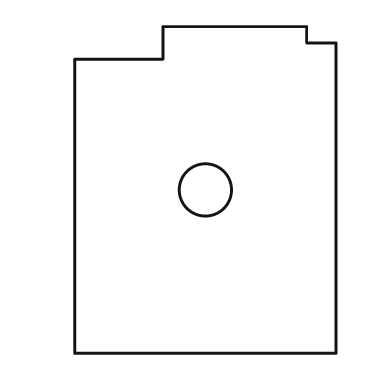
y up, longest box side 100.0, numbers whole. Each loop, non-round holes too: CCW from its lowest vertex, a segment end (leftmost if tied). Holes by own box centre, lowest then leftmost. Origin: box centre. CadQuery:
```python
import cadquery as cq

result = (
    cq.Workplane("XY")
    .moveTo(-40.0, -50.0)
    .lineTo(40.0, -50.0)
    .lineTo(40.0, 45.0)
    .lineTo(31.0, 45.0)
    .lineTo(31.0, 50.0)
    .lineTo(-13.0, 50.0)
    .lineTo(-13.0, 40.0)
    .lineTo(-40.0, 40.0)
    .close()
    .moveTo(0.0, 0.0)
    .circle(8.0)
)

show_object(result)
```